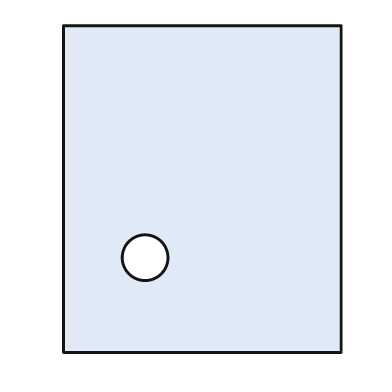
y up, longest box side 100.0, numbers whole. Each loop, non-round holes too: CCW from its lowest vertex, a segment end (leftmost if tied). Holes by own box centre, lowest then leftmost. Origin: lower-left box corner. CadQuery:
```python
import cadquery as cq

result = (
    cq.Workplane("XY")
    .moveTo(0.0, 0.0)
    .lineTo(85.0, 0.0)
    .lineTo(85.0, 100.0)
    .lineTo(0.0, 100.0)
    .close()
    .moveTo(25.0, 29.0)
    .circle(7.0)
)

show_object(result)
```